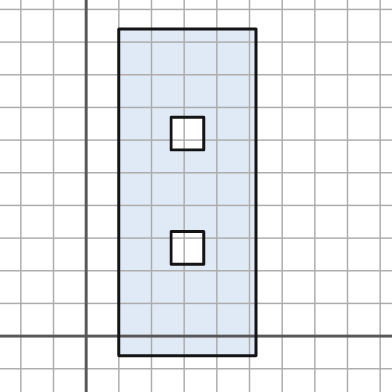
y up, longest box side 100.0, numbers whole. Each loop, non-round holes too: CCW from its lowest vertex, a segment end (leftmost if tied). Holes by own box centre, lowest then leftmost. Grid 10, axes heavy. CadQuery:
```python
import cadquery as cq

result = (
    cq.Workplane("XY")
    .moveTo(10.0, -6.0)
    .lineTo(52.0, -6.0)
    .lineTo(52.0, 94.0)
    .lineTo(10.0, 94.0)
    .close()
    .moveTo(26.0, 22.0)
    .lineTo(36.0, 22.0)
    .lineTo(36.0, 32.0)
    .lineTo(26.0, 32.0)
    .close()
    .moveTo(26.0, 57.0)
    .lineTo(36.0, 57.0)
    .lineTo(36.0, 67.0)
    .lineTo(26.0, 67.0)
    .close()
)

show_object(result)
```